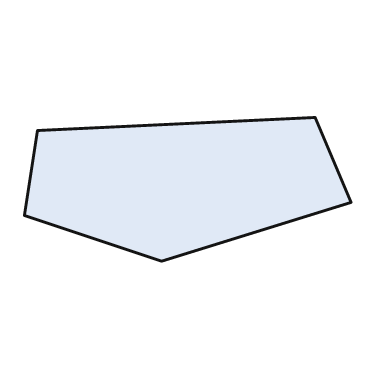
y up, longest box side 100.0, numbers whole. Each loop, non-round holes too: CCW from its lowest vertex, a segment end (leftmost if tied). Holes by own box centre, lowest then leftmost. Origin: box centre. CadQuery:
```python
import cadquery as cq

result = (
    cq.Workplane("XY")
    .moveTo(-8.0, -22.0)
    .lineTo(50.0, -4.0)
    .lineTo(39.0, 22.0)
    .lineTo(-46.0, 18.0)
    .lineTo(-50.0, -8.0)
    .close()
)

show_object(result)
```